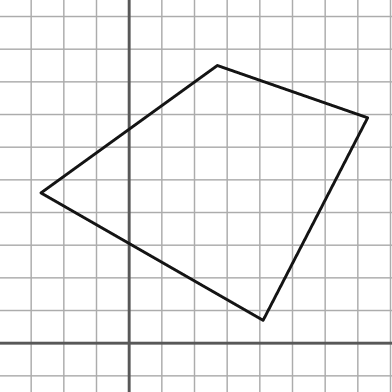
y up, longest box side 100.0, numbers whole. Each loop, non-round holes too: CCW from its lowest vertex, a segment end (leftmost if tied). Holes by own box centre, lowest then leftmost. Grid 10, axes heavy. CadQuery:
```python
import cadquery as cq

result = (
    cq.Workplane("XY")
    .moveTo(41.0, 7.0)
    .lineTo(73.0, 69.0)
    .lineTo(27.0, 85.0)
    .lineTo(-27.0, 46.0)
    .close()
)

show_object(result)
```